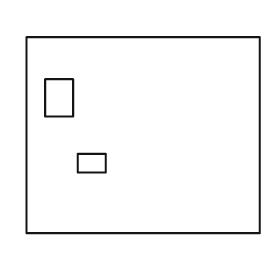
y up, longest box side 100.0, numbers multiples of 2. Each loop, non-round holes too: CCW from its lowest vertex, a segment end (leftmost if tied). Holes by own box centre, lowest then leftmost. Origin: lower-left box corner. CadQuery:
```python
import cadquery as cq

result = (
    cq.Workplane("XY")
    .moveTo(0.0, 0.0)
    .lineTo(100.0, 0.0)
    .lineTo(100.0, 84.0)
    .lineTo(0.0, 84.0)
    .close()
    .moveTo(22.0, 26.0)
    .lineTo(34.0, 26.0)
    .lineTo(34.0, 34.0)
    .lineTo(22.0, 34.0)
    .close()
    .moveTo(8.0, 50.0)
    .lineTo(20.0, 50.0)
    .lineTo(20.0, 66.0)
    .lineTo(8.0, 66.0)
    .close()
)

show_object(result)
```